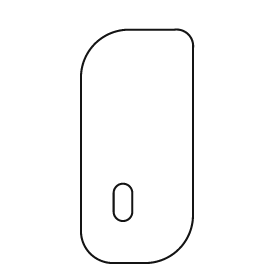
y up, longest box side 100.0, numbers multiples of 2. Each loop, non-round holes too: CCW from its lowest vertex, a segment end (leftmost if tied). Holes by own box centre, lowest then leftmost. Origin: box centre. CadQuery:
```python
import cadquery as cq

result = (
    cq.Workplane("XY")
    .moveTo(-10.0, -50.0)
    .lineTo(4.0, -50.0)
    .threePointArc((18.0, -44.0), (24.0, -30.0))
    .lineTo(24.0, 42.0)
    .threePointArc((22.0, 48.0), (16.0, 50.0))
    .lineTo(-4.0, 50.0)
    .threePointArc((-18.0, 44.0), (-24.0, 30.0))
    .lineTo(-24.0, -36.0)
    .threePointArc((-20.0, -46.0), (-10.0, -50.0))
    .close()
    .moveTo(-10.0, -28.0)
    .threePointArc((-6.0, -32.0), (-2.0, -28.0))
    .lineTo(-2.0, -20.0)
    .threePointArc((-6.0, -16.0), (-10.0, -20.0))
    .close()
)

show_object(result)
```